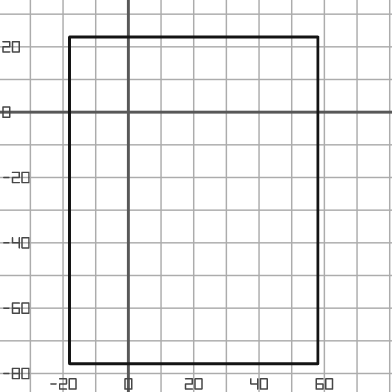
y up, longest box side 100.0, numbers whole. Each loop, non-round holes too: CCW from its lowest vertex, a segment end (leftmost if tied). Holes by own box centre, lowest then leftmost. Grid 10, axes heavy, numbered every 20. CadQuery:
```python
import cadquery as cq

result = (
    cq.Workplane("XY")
    .moveTo(-18.0, -77.0)
    .lineTo(58.0, -77.0)
    .lineTo(58.0, 23.0)
    .lineTo(-18.0, 23.0)
    .close()
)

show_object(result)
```